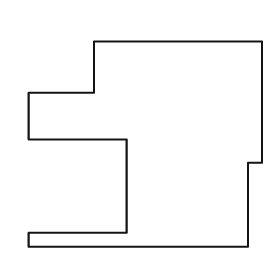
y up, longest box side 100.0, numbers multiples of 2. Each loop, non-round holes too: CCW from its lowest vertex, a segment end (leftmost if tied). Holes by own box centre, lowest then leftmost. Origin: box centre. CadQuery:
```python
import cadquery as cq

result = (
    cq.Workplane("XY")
    .moveTo(-50.0, -44.0)
    .lineTo(44.0, -44.0)
    .lineTo(44.0, -8.0)
    .lineTo(50.0, -8.0)
    .lineTo(50.0, 44.0)
    .lineTo(-22.0, 44.0)
    .lineTo(-22.0, 22.0)
    .lineTo(-50.0, 22.0)
    .lineTo(-50.0, 2.0)
    .lineTo(-8.0, 2.0)
    .lineTo(-8.0, -38.0)
    .lineTo(-50.0, -38.0)
    .close()
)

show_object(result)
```